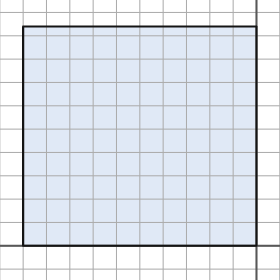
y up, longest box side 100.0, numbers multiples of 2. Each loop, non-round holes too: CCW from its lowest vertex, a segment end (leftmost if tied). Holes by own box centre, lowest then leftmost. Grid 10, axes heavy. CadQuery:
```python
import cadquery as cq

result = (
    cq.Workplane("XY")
    .moveTo(-100.0, 0.0)
    .lineTo(0.0, 0.0)
    .lineTo(0.0, 94.0)
    .lineTo(-100.0, 94.0)
    .close()
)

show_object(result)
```